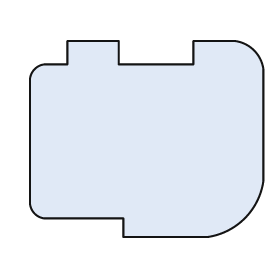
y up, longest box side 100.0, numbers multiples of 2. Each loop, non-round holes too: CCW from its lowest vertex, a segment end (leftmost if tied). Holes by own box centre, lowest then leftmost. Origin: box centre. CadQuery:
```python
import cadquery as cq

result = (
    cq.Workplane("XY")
    .moveTo(-10.0, -42.0)
    .lineTo(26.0, -42.0)
    .threePointArc((42.0, -34.0), (50.0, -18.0))
    .lineTo(50.0, 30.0)
    .threePointArc((46.0, 38.0), (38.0, 42.0))
    .lineTo(20.0, 42.0)
    .lineTo(20.0, 32.0)
    .lineTo(-12.0, 32.0)
    .lineTo(-12.0, 42.0)
    .lineTo(-34.0, 42.0)
    .lineTo(-34.0, 32.0)
    .lineTo(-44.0, 32.0)
    .threePointArc((-48.0, 30.0), (-50.0, 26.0))
    .lineTo(-50.0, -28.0)
    .threePointArc((-48.0, -32.0), (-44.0, -34.0))
    .lineTo(-10.0, -34.0)
    .close()
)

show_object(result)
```